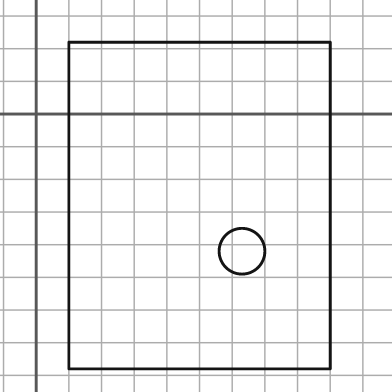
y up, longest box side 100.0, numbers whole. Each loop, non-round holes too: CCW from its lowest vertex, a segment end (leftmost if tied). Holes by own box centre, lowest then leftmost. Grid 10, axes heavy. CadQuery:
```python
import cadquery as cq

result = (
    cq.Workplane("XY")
    .moveTo(10.0, -78.0)
    .lineTo(90.0, -78.0)
    .lineTo(90.0, 22.0)
    .lineTo(10.0, 22.0)
    .close()
    .moveTo(63.0, -42.0)
    .circle(7.0)
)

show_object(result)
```